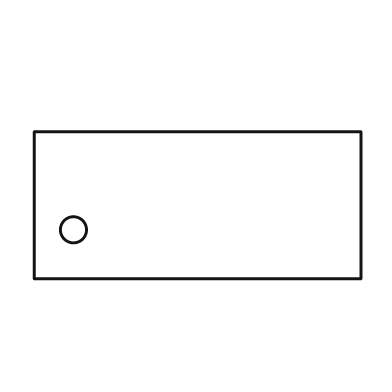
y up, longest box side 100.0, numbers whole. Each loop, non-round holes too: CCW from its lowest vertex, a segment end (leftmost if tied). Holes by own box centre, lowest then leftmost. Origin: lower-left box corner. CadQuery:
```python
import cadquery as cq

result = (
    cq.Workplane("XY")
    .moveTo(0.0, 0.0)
    .lineTo(100.0, 0.0)
    .lineTo(100.0, 45.0)
    .lineTo(0.0, 45.0)
    .close()
    .moveTo(12.0, 15.0)
    .circle(4.0)
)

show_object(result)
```